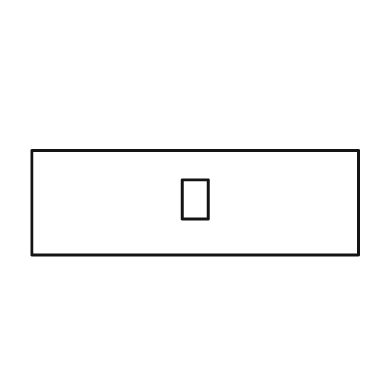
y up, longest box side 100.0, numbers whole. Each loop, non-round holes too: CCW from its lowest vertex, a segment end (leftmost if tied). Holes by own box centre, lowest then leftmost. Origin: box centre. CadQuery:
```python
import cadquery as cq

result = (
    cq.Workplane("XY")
    .moveTo(-50.0, -16.0)
    .lineTo(50.0, -16.0)
    .lineTo(50.0, 16.0)
    .lineTo(-50.0, 16.0)
    .close()
    .moveTo(-4.0, -5.0)
    .lineTo(4.0, -5.0)
    .lineTo(4.0, 7.0)
    .lineTo(-4.0, 7.0)
    .close()
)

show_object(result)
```